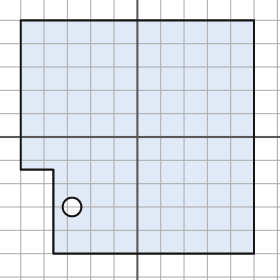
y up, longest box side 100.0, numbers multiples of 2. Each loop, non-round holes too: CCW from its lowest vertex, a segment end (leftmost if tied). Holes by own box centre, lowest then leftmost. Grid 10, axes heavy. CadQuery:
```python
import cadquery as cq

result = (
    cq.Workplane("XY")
    .moveTo(-36.0, -50.0)
    .lineTo(50.0, -50.0)
    .lineTo(50.0, 50.0)
    .lineTo(-50.0, 50.0)
    .lineTo(-50.0, -14.0)
    .lineTo(-36.0, -14.0)
    .close()
    .moveTo(-28.0, -30.0)
    .circle(4.0)
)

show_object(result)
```